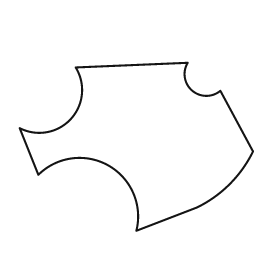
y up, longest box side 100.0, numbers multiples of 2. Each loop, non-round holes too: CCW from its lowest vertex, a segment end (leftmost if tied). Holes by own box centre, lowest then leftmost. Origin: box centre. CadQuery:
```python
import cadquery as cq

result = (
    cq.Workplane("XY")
    .moveTo(0.0, -36.0)
    .lineTo(26.0, -26.0)
    .threePointArc((40.0, -16.0), (50.0, -2.0))
    .lineTo(36.0, 24.0)
    .threePointArc((24.0, 24.0), (22.0, 36.0))
    .lineTo(-26.0, 34.0)
    .threePointArc((-28.0, 12.0), (-50.0, 8.0))
    .lineTo(-42.0, -12.0)
    .threePointArc((-12.0, -8.0), (0.0, -36.0))
    .close()
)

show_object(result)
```